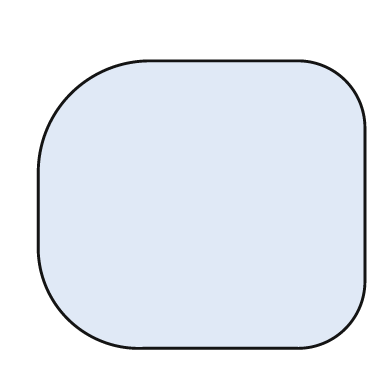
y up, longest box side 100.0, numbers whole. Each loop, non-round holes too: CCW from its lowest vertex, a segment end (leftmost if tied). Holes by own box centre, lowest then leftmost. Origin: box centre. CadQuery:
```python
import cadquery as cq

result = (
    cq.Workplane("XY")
    .moveTo(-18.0, -44.0)
    .lineTo(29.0, -44.0)
    .threePointArc((44.0, -38.0), (50.0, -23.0))
    .lineTo(50.0, 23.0)
    .threePointArc((44.0, 38.0), (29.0, 44.0))
    .lineTo(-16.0, 44.0)
    .threePointArc((-40.0, 34.0), (-50.0, 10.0))
    .lineTo(-50.0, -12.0)
    .threePointArc((-41.0, -35.0), (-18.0, -44.0))
    .close()
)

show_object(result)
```